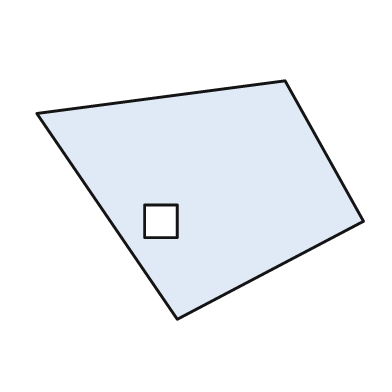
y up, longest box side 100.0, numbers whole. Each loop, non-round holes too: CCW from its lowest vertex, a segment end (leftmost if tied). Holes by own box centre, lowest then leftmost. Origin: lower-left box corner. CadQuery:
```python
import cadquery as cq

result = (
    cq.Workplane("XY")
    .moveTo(43.0, 0.0)
    .lineTo(100.0, 30.0)
    .lineTo(76.0, 73.0)
    .lineTo(0.0, 63.0)
    .close()
    .moveTo(33.0, 25.0)
    .lineTo(43.0, 25.0)
    .lineTo(43.0, 35.0)
    .lineTo(33.0, 35.0)
    .close()
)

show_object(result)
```